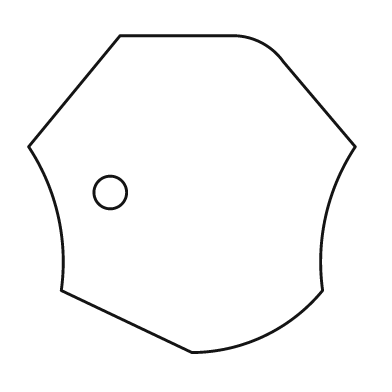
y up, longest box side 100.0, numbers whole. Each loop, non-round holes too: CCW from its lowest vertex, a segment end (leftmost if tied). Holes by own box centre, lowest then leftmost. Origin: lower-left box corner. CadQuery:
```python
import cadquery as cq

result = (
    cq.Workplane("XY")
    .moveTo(50.0, 0.0)
    .threePointArc((72.0, 5.0), (90.0, 19.0))
    .threePointArc((91.0, 42.0), (100.0, 63.0))
    .lineTo(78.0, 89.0)
    .threePointArc((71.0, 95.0), (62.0, 97.0))
    .lineTo(28.0, 97.0)
    .lineTo(0.0, 63.0)
    .threePointArc((9.0, 42.0), (10.0, 19.0))
    .close()
    .moveTo(25.0, 49.0)
    .circle(5.0)
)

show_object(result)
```